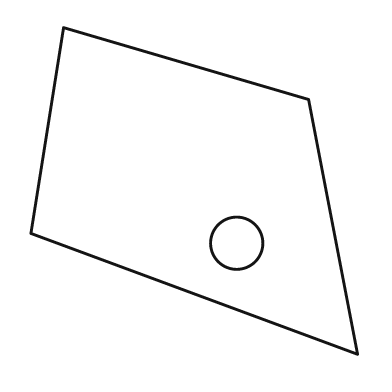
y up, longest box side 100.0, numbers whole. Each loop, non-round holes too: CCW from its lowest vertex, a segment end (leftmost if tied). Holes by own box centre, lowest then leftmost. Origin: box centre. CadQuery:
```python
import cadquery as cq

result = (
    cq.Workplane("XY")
    .moveTo(50.0, -50.0)
    .lineTo(35.0, 28.0)
    .lineTo(-40.0, 50.0)
    .lineTo(-50.0, -13.0)
    .close()
    .moveTo(13.0, -16.0)
    .circle(8.0)
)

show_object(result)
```